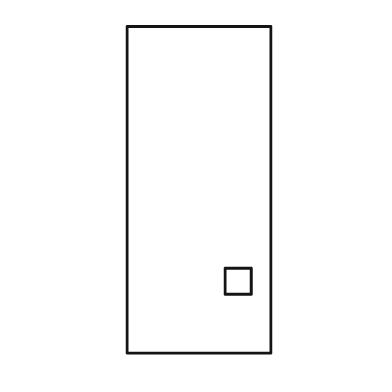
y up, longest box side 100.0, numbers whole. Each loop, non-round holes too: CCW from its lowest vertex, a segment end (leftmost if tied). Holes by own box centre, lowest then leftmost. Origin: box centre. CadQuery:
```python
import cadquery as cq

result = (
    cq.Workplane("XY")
    .moveTo(-22.0, -50.0)
    .lineTo(22.0, -50.0)
    .lineTo(22.0, 50.0)
    .lineTo(-22.0, 50.0)
    .close()
    .moveTo(8.0, -32.0)
    .lineTo(16.0, -32.0)
    .lineTo(16.0, -24.0)
    .lineTo(8.0, -24.0)
    .close()
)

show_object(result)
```